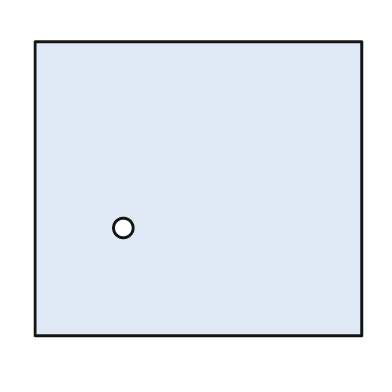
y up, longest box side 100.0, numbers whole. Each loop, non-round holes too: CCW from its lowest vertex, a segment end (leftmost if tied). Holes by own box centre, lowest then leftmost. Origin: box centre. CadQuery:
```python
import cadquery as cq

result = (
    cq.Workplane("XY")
    .moveTo(-50.0, -45.0)
    .lineTo(50.0, -45.0)
    .lineTo(50.0, 45.0)
    .lineTo(-50.0, 45.0)
    .close()
    .moveTo(-23.0, -12.0)
    .circle(3.0)
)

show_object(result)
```